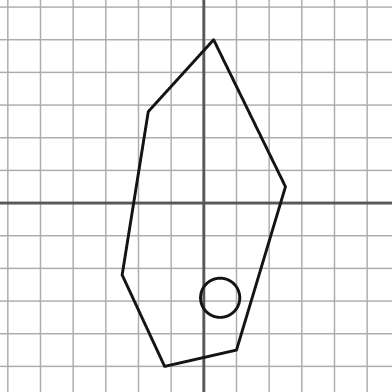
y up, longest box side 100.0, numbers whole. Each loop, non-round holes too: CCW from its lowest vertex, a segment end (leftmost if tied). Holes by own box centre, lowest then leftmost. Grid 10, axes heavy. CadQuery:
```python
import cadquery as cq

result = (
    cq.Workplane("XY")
    .moveTo(-12.0, -50.0)
    .lineTo(10.0, -45.0)
    .lineTo(25.0, 5.0)
    .lineTo(3.0, 50.0)
    .lineTo(-17.0, 28.0)
    .lineTo(-25.0, -22.0)
    .close()
    .moveTo(5.0, -29.0)
    .circle(6.0)
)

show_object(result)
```